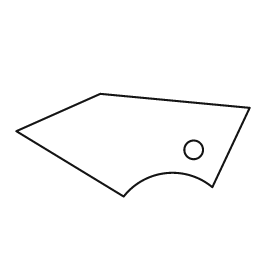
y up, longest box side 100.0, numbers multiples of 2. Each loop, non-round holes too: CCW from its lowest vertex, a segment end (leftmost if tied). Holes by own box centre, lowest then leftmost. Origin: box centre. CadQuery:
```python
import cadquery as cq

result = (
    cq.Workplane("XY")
    .moveTo(-4.0, -22.0)
    .threePointArc((14.0, -12.0), (34.0, -18.0))
    .lineTo(50.0, 16.0)
    .lineTo(-14.0, 22.0)
    .lineTo(-50.0, 6.0)
    .close()
    .moveTo(26.0, -2.0)
    .circle(4.0)
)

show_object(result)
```